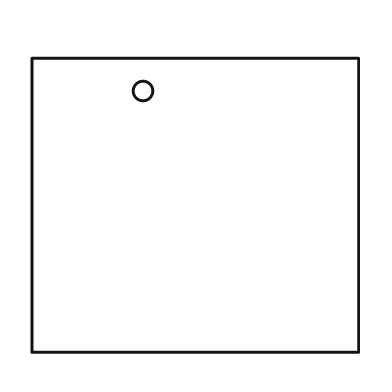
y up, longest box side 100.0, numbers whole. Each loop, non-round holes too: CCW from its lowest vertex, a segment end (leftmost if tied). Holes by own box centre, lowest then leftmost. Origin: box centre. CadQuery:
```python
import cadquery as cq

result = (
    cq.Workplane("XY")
    .moveTo(-50.0, -45.0)
    .lineTo(50.0, -45.0)
    .lineTo(50.0, 45.0)
    .lineTo(-50.0, 45.0)
    .close()
    .moveTo(-16.0, 35.0)
    .circle(3.0)
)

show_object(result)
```